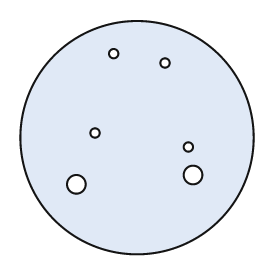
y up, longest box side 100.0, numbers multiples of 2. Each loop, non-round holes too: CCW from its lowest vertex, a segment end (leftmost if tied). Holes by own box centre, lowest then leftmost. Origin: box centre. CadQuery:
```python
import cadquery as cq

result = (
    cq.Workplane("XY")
    .moveTo(0.0, 0.0)
    .circle(50.0)
    .moveTo(-26.0, -20.0)
    .circle(4.0)
    .moveTo(24.0, -16.0)
    .circle(4.0)
    .moveTo(22.0, -4.0)
    .circle(2.0)
    .moveTo(-18.0, 2.0)
    .circle(2.0)
    .moveTo(12.0, 32.0)
    .circle(2.0)
    .moveTo(-10.0, 36.0)
    .circle(2.0)
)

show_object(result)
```